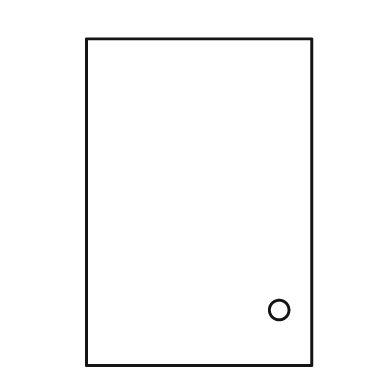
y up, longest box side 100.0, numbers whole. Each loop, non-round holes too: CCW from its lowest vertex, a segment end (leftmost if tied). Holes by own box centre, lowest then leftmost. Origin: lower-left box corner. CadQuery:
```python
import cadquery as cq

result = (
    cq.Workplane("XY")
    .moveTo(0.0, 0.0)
    .lineTo(69.0, 0.0)
    .lineTo(69.0, 100.0)
    .lineTo(0.0, 100.0)
    .close()
    .moveTo(59.0, 17.0)
    .circle(3.0)
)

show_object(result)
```